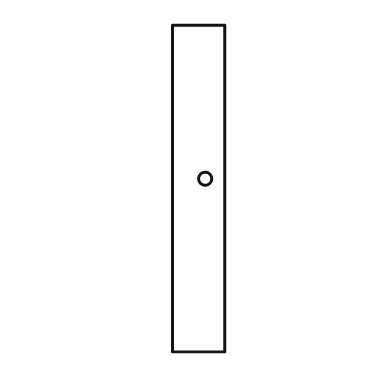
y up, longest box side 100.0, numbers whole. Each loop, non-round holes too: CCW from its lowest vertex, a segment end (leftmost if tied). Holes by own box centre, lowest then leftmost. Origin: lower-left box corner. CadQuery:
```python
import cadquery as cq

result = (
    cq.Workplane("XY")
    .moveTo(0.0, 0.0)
    .lineTo(16.0, 0.0)
    .lineTo(16.0, 100.0)
    .lineTo(0.0, 100.0)
    .close()
    .moveTo(10.0, 53.0)
    .circle(2.0)
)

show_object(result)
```